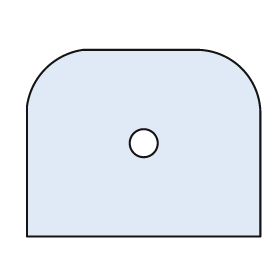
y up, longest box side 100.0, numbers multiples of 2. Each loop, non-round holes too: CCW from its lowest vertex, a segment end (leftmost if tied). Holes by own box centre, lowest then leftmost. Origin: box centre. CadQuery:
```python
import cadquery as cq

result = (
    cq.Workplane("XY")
    .moveTo(-50.0, -40.0)
    .lineTo(50.0, -40.0)
    .lineTo(50.0, 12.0)
    .threePointArc((42.0, 32.0), (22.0, 40.0))
    .lineTo(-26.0, 40.0)
    .threePointArc((-42.0, 32.0), (-50.0, 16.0))
    .close()
    .moveTo(0.0, 0.0)
    .circle(6.0)
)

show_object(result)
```